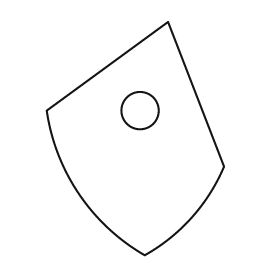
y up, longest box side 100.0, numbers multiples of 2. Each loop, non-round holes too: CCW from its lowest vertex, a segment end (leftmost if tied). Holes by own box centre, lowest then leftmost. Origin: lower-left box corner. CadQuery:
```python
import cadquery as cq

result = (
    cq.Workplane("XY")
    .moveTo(42.0, 0.0)
    .threePointArc((62.0, 16.0), (76.0, 38.0))
    .lineTo(52.0, 100.0)
    .lineTo(0.0, 62.0)
    .threePointArc((14.0, 26.0), (42.0, 0.0))
    .close()
    .moveTo(40.0, 62.0)
    .circle(8.0)
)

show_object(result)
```